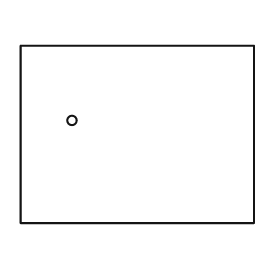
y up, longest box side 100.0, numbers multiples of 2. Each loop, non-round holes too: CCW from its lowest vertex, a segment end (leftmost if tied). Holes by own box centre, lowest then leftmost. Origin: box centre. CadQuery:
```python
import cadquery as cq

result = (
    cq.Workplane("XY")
    .moveTo(-50.0, -38.0)
    .lineTo(50.0, -38.0)
    .lineTo(50.0, 38.0)
    .lineTo(-50.0, 38.0)
    .close()
    .moveTo(-28.0, 6.0)
    .circle(2.0)
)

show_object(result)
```